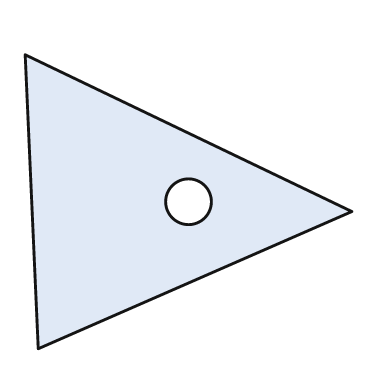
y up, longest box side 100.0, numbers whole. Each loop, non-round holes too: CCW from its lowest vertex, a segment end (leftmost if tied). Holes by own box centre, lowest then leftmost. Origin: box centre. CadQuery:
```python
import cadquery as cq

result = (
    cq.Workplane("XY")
    .moveTo(-46.0, -45.0)
    .lineTo(50.0, -3.0)
    .lineTo(-50.0, 45.0)
    .close()
    .moveTo(0.0, 0.0)
    .circle(7.0)
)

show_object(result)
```